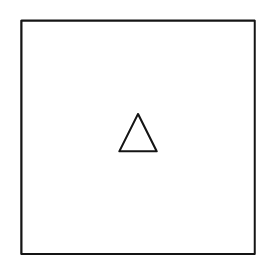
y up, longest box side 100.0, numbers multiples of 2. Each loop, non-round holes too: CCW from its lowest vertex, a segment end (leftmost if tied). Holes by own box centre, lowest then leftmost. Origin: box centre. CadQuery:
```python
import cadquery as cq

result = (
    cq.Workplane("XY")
    .moveTo(-50.0, -50.0)
    .lineTo(50.0, -50.0)
    .lineTo(50.0, 50.0)
    .lineTo(-50.0, 50.0)
    .close()
    .moveTo(-8.0, -6.0)
    .lineTo(8.0, -6.0)
    .lineTo(0.0, 10.0)
    .close()
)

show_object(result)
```